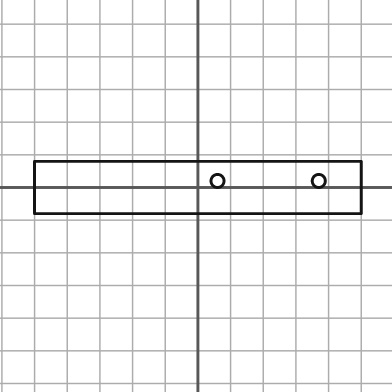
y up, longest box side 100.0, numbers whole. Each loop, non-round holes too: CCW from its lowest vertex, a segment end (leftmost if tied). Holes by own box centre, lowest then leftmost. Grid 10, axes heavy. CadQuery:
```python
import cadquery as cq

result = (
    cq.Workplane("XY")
    .moveTo(-50.0, -8.0)
    .lineTo(50.0, -8.0)
    .lineTo(50.0, 8.0)
    .lineTo(-50.0, 8.0)
    .close()
    .moveTo(6.0, 2.0)
    .circle(2.0)
    .moveTo(37.0, 2.0)
    .circle(2.0)
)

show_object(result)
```